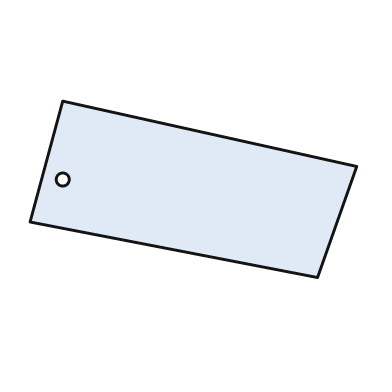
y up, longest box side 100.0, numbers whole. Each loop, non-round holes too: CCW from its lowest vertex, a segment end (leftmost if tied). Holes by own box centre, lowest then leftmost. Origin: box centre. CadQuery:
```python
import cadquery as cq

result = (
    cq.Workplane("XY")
    .moveTo(38.0, -27.0)
    .lineTo(50.0, 7.0)
    .lineTo(-40.0, 27.0)
    .lineTo(-50.0, -10.0)
    .close()
    .moveTo(-40.0, 3.0)
    .circle(2.0)
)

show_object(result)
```